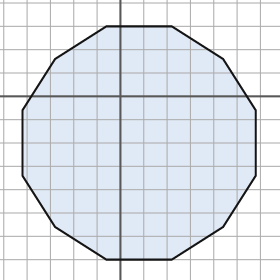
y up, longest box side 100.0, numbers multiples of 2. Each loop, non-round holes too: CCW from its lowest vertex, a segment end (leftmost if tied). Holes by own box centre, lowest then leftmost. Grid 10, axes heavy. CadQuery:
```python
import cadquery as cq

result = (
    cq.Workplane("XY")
    .moveTo(-6.0, -70.0)
    .lineTo(22.0, -70.0)
    .lineTo(44.0, -56.0)
    .lineTo(58.0, -34.0)
    .lineTo(58.0, -6.0)
    .lineTo(44.0, 16.0)
    .lineTo(22.0, 30.0)
    .lineTo(-6.0, 30.0)
    .lineTo(-28.0, 16.0)
    .lineTo(-42.0, -6.0)
    .lineTo(-42.0, -34.0)
    .lineTo(-28.0, -56.0)
    .close()
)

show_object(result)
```